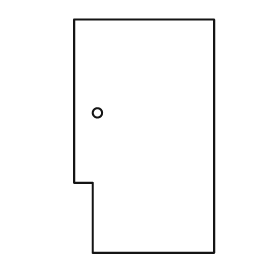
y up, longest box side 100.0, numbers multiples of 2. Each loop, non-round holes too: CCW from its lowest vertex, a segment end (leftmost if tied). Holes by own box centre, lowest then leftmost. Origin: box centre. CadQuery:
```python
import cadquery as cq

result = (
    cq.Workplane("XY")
    .moveTo(-22.0, -50.0)
    .lineTo(30.0, -50.0)
    .lineTo(30.0, 50.0)
    .lineTo(-30.0, 50.0)
    .lineTo(-30.0, -20.0)
    .lineTo(-22.0, -20.0)
    .close()
    .moveTo(-20.0, 10.0)
    .circle(2.0)
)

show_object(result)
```